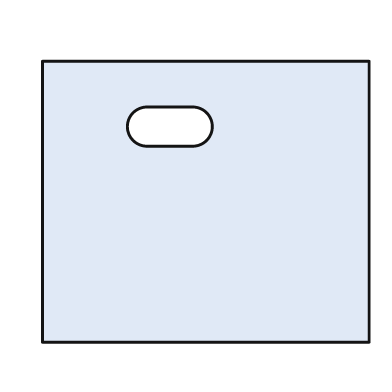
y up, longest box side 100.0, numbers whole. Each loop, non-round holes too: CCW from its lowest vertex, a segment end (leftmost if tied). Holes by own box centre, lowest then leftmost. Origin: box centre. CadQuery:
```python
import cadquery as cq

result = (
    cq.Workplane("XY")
    .moveTo(-50.0, -43.0)
    .lineTo(50.0, -43.0)
    .lineTo(50.0, 43.0)
    .lineTo(-50.0, 43.0)
    .close()
    .moveTo(-18.0, 17.0)
    .lineTo(-4.0, 17.0)
    .threePointArc((2.0, 23.0), (-4.0, 29.0))
    .lineTo(-18.0, 29.0)
    .threePointArc((-24.0, 23.0), (-18.0, 17.0))
    .close()
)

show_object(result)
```